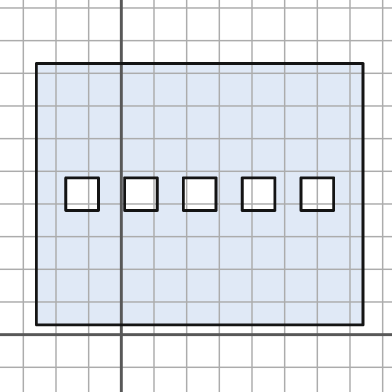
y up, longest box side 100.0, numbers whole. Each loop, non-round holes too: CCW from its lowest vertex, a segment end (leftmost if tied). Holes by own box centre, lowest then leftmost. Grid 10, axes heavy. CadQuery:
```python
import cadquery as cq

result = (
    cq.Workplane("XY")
    .moveTo(-26.0, 3.0)
    .lineTo(74.0, 3.0)
    .lineTo(74.0, 83.0)
    .lineTo(-26.0, 83.0)
    .close()
    .moveTo(-17.0, 38.0)
    .lineTo(-7.0, 38.0)
    .lineTo(-7.0, 48.0)
    .lineTo(-17.0, 48.0)
    .close()
    .moveTo(1.0, 38.0)
    .lineTo(11.0, 38.0)
    .lineTo(11.0, 48.0)
    .lineTo(1.0, 48.0)
    .close()
    .moveTo(19.0, 38.0)
    .lineTo(29.0, 38.0)
    .lineTo(29.0, 48.0)
    .lineTo(19.0, 48.0)
    .close()
    .moveTo(37.0, 38.0)
    .lineTo(47.0, 38.0)
    .lineTo(47.0, 48.0)
    .lineTo(37.0, 48.0)
    .close()
    .moveTo(55.0, 38.0)
    .lineTo(65.0, 38.0)
    .lineTo(65.0, 48.0)
    .lineTo(55.0, 48.0)
    .close()
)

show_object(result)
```